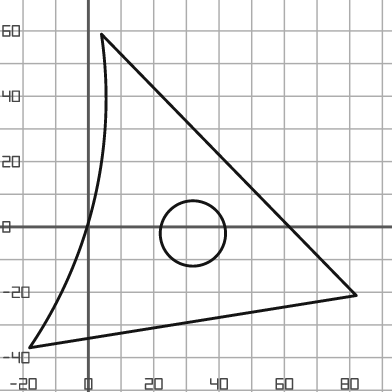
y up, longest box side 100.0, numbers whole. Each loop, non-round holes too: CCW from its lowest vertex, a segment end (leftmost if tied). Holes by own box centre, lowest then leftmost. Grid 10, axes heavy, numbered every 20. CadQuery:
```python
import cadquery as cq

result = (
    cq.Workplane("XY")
    .moveTo(-18.0, -37.0)
    .lineTo(82.0, -21.0)
    .lineTo(4.0, 59.0)
    .threePointArc((2.0, 9.0), (-18.0, -37.0))
    .close()
    .moveTo(32.0, -2.0)
    .circle(10.0)
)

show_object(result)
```